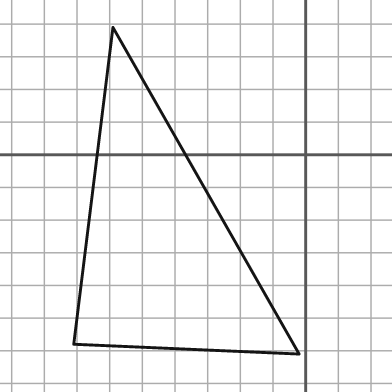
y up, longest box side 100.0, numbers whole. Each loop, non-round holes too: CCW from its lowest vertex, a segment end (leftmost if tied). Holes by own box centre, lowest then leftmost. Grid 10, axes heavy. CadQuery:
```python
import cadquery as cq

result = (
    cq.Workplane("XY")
    .moveTo(-2.0, -61.0)
    .lineTo(-59.0, 39.0)
    .lineTo(-71.0, -58.0)
    .close()
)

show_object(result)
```